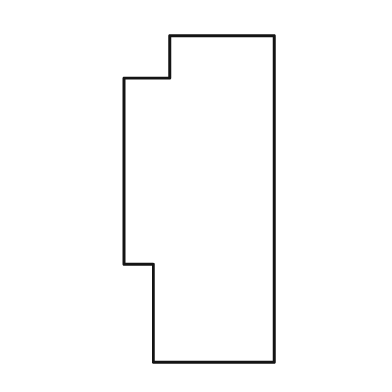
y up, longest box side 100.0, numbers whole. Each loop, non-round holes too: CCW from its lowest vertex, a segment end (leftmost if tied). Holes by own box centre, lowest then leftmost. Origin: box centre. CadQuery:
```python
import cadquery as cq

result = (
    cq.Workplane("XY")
    .moveTo(-14.0, -50.0)
    .lineTo(23.0, -50.0)
    .lineTo(23.0, 50.0)
    .lineTo(-9.0, 50.0)
    .lineTo(-9.0, 37.0)
    .lineTo(-23.0, 37.0)
    .lineTo(-23.0, -20.0)
    .lineTo(-14.0, -20.0)
    .close()
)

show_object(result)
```